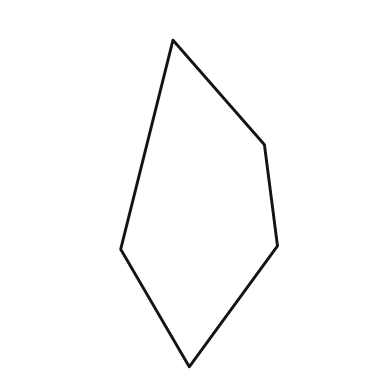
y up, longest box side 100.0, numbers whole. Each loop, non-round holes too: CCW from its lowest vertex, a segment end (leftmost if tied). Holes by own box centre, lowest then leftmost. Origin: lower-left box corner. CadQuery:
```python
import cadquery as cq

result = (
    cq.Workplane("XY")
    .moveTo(21.0, 0.0)
    .lineTo(48.0, 37.0)
    .lineTo(44.0, 68.0)
    .lineTo(16.0, 100.0)
    .lineTo(0.0, 36.0)
    .close()
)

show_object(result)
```